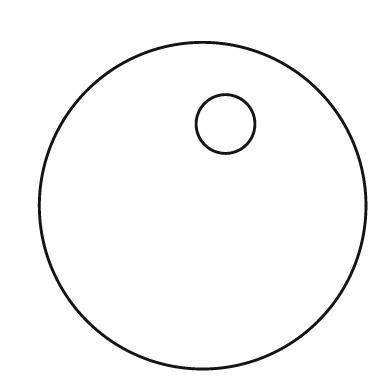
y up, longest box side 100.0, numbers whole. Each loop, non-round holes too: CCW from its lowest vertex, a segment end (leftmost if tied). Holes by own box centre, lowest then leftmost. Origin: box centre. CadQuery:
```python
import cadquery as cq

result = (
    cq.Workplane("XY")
    .moveTo(0.0, 0.0)
    .circle(50.0)
    .moveTo(7.0, 25.0)
    .circle(9.0)
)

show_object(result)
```